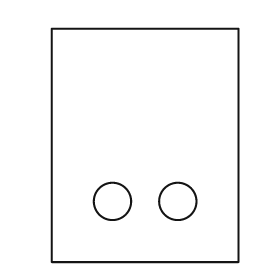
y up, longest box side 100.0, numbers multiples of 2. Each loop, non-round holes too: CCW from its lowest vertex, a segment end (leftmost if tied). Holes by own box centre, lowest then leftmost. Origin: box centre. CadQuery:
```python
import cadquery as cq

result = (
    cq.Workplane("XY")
    .moveTo(-40.0, -50.0)
    .lineTo(40.0, -50.0)
    .lineTo(40.0, 50.0)
    .lineTo(-40.0, 50.0)
    .close()
    .moveTo(-14.0, -24.0)
    .circle(8.0)
    .moveTo(14.0, -24.0)
    .circle(8.0)
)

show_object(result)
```